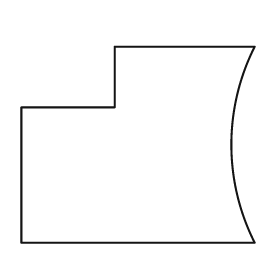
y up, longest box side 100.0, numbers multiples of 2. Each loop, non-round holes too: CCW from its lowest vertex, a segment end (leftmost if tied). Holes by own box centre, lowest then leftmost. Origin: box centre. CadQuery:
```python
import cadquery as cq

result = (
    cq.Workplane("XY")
    .moveTo(-50.0, -42.0)
    .lineTo(50.0, -42.0)
    .threePointArc((40.0, 0.0), (50.0, 42.0))
    .lineTo(-10.0, 42.0)
    .lineTo(-10.0, 16.0)
    .lineTo(-50.0, 16.0)
    .close()
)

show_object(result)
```